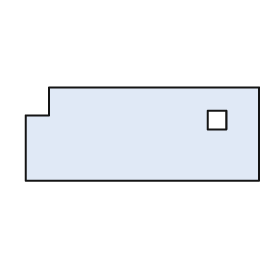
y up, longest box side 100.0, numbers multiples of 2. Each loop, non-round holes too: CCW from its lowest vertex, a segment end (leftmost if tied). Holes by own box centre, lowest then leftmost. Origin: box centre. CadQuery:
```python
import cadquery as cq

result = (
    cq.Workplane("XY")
    .moveTo(-50.0, -20.0)
    .lineTo(50.0, -20.0)
    .lineTo(50.0, 20.0)
    .lineTo(-40.0, 20.0)
    .lineTo(-40.0, 8.0)
    .lineTo(-50.0, 8.0)
    .close()
    .moveTo(28.0, 2.0)
    .lineTo(36.0, 2.0)
    .lineTo(36.0, 10.0)
    .lineTo(28.0, 10.0)
    .close()
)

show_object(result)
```